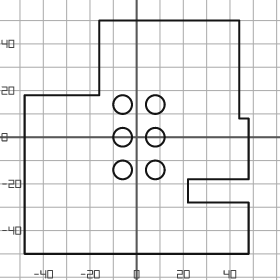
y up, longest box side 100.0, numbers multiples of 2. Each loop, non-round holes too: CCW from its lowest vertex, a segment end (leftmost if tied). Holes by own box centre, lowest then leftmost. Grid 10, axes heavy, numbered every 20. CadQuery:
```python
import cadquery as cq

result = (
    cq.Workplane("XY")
    .moveTo(-48.0, -50.0)
    .lineTo(48.0, -50.0)
    .lineTo(48.0, -28.0)
    .lineTo(22.0, -28.0)
    .lineTo(22.0, -18.0)
    .lineTo(48.0, -18.0)
    .lineTo(48.0, 8.0)
    .lineTo(44.0, 8.0)
    .lineTo(44.0, 50.0)
    .lineTo(-16.0, 50.0)
    .lineTo(-16.0, 18.0)
    .lineTo(-48.0, 18.0)
    .close()
    .moveTo(-6.0, -14.0)
    .circle(4.0)
    .moveTo(8.0, -14.0)
    .circle(4.0)
    .moveTo(-6.0, 0.0)
    .circle(4.0)
    .moveTo(8.0, 0.0)
    .circle(4.0)
    .moveTo(-6.0, 14.0)
    .circle(4.0)
    .moveTo(8.0, 14.0)
    .circle(4.0)
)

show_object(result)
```